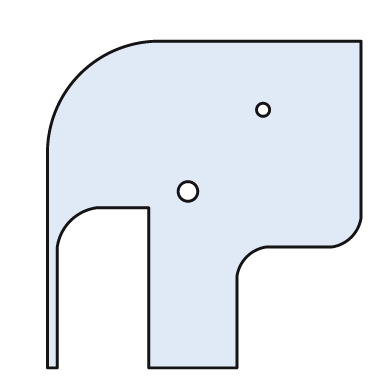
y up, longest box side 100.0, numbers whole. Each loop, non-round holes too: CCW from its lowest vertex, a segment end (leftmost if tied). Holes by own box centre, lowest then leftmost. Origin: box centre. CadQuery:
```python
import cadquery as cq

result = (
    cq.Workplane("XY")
    .moveTo(-48.0, -50.0)
    .lineTo(-45.0, -50.0)
    .lineTo(-45.0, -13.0)
    .threePointArc((-41.0, -5.0), (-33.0, -1.0))
    .lineTo(-17.0, -1.0)
    .lineTo(-17.0, -50.0)
    .lineTo(10.0, -50.0)
    .lineTo(10.0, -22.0)
    .threePointArc((13.0, -16.0), (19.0, -13.0))
    .lineTo(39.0, -13.0)
    .threePointArc((45.0, -10.0), (48.0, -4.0))
    .lineTo(48.0, 50.0)
    .lineTo(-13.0, 50.0)
    .threePointArc((-38.0, 40.0), (-48.0, 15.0))
    .close()
    .moveTo(-5.0, 4.0)
    .circle(3.0)
    .moveTo(18.0, 29.0)
    .circle(2.0)
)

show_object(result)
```